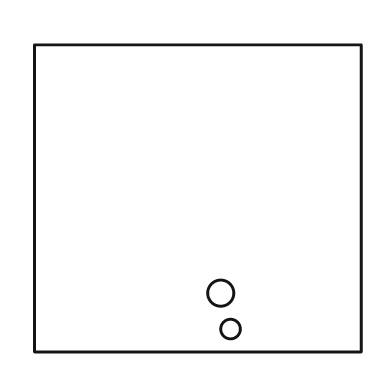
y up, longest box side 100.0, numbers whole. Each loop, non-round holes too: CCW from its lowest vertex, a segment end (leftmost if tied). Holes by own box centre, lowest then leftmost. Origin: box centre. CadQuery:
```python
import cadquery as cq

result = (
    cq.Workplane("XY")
    .moveTo(-50.0, -47.0)
    .lineTo(50.0, -47.0)
    .lineTo(50.0, 47.0)
    .lineTo(-50.0, 47.0)
    .close()
    .moveTo(10.0, -40.0)
    .circle(3.0)
    .moveTo(7.0, -29.0)
    .circle(4.0)
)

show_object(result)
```